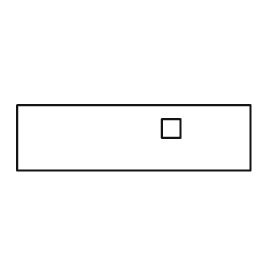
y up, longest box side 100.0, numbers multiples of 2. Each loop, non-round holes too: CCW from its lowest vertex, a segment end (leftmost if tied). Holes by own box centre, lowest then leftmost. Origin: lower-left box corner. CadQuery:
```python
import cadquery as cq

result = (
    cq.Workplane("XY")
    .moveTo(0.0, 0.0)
    .lineTo(100.0, 0.0)
    .lineTo(100.0, 28.0)
    .lineTo(0.0, 28.0)
    .close()
    .moveTo(62.0, 14.0)
    .lineTo(70.0, 14.0)
    .lineTo(70.0, 22.0)
    .lineTo(62.0, 22.0)
    .close()
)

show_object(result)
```